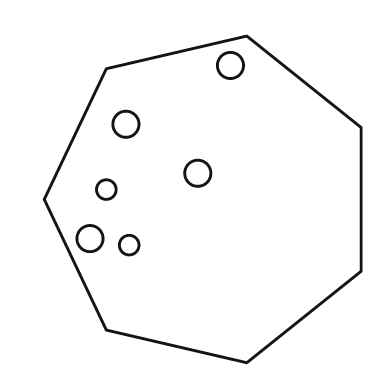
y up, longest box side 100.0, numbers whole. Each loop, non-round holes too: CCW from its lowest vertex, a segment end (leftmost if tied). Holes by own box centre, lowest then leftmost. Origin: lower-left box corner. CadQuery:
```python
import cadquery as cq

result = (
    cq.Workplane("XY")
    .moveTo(62.0, 0.0)
    .lineTo(97.0, 28.0)
    .lineTo(97.0, 72.0)
    .lineTo(62.0, 100.0)
    .lineTo(19.0, 90.0)
    .lineTo(0.0, 50.0)
    .lineTo(19.0, 10.0)
    .close()
    .moveTo(26.0, 36.0)
    .circle(3.0)
    .moveTo(14.0, 38.0)
    .circle(4.0)
    .moveTo(19.0, 53.0)
    .circle(3.0)
    .moveTo(47.0, 58.0)
    .circle(4.0)
    .moveTo(25.0, 73.0)
    .circle(4.0)
    .moveTo(57.0, 91.0)
    .circle(4.0)
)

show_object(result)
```